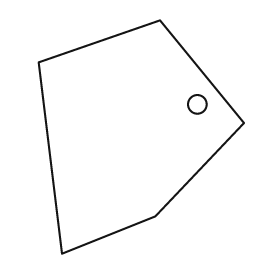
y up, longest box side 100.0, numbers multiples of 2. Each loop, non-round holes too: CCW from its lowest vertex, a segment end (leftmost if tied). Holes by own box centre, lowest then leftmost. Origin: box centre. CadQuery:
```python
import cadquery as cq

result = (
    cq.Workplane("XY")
    .moveTo(-34.0, -50.0)
    .lineTo(6.0, -34.0)
    .lineTo(44.0, 6.0)
    .lineTo(8.0, 50.0)
    .lineTo(-44.0, 32.0)
    .close()
    .moveTo(24.0, 14.0)
    .circle(4.0)
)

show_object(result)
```